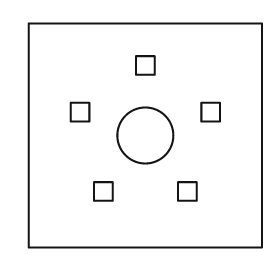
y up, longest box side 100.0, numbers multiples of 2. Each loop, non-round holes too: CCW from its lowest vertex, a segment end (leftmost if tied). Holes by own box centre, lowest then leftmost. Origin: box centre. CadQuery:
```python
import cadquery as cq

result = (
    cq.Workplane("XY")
    .moveTo(-50.0, -48.0)
    .lineTo(50.0, -48.0)
    .lineTo(50.0, 48.0)
    .lineTo(-50.0, 48.0)
    .close()
    .moveTo(-22.0, -28.0)
    .lineTo(-14.0, -28.0)
    .lineTo(-14.0, -20.0)
    .lineTo(-22.0, -20.0)
    .close()
    .moveTo(14.0, -28.0)
    .lineTo(22.0, -28.0)
    .lineTo(22.0, -20.0)
    .lineTo(14.0, -20.0)
    .close()
    .moveTo(0.0, 0.0)
    .circle(12.0)
    .moveTo(-32.0, 6.0)
    .lineTo(-24.0, 6.0)
    .lineTo(-24.0, 14.0)
    .lineTo(-32.0, 14.0)
    .close()
    .moveTo(24.0, 6.0)
    .lineTo(32.0, 6.0)
    .lineTo(32.0, 14.0)
    .lineTo(24.0, 14.0)
    .close()
    .moveTo(-4.0, 26.0)
    .lineTo(4.0, 26.0)
    .lineTo(4.0, 34.0)
    .lineTo(-4.0, 34.0)
    .close()
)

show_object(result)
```